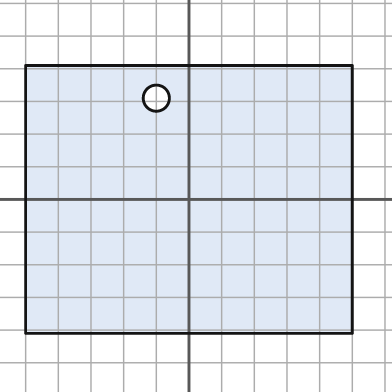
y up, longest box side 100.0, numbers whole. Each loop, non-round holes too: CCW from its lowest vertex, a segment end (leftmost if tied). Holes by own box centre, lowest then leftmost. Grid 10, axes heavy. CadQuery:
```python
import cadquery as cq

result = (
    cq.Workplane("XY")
    .moveTo(-50.0, -41.0)
    .lineTo(50.0, -41.0)
    .lineTo(50.0, 41.0)
    .lineTo(-50.0, 41.0)
    .close()
    .moveTo(-10.0, 31.0)
    .circle(4.0)
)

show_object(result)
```